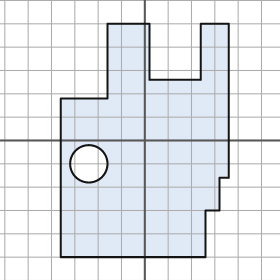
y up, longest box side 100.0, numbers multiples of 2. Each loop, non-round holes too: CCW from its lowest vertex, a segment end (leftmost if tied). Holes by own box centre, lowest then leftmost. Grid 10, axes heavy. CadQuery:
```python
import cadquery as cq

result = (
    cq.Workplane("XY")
    .moveTo(-36.0, -50.0)
    .lineTo(26.0, -50.0)
    .lineTo(26.0, -30.0)
    .lineTo(32.0, -30.0)
    .lineTo(32.0, -16.0)
    .lineTo(36.0, -16.0)
    .lineTo(36.0, 50.0)
    .lineTo(24.0, 50.0)
    .lineTo(24.0, 26.0)
    .lineTo(2.0, 26.0)
    .lineTo(2.0, 50.0)
    .lineTo(-16.0, 50.0)
    .lineTo(-16.0, 18.0)
    .lineTo(-36.0, 18.0)
    .close()
    .moveTo(-24.0, -10.0)
    .circle(8.0)
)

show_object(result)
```